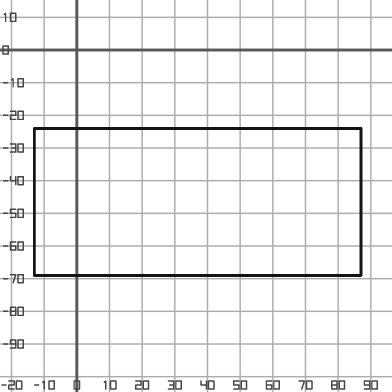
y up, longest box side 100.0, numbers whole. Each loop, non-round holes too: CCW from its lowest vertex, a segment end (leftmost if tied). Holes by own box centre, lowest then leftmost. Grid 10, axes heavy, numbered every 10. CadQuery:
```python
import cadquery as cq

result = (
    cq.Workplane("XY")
    .moveTo(-13.0, -69.0)
    .lineTo(87.0, -69.0)
    .lineTo(87.0, -24.0)
    .lineTo(-13.0, -24.0)
    .close()
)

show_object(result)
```